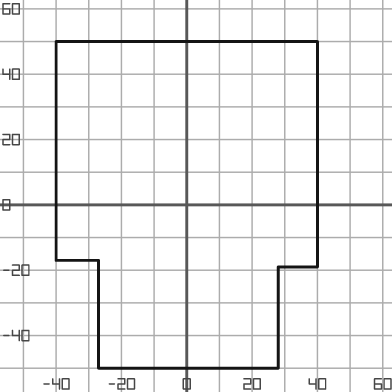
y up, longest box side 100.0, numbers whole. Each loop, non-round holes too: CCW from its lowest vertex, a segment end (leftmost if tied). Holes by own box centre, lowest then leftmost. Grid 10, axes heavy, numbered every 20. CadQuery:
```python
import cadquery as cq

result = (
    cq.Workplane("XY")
    .moveTo(-27.0, -50.0)
    .lineTo(28.0, -50.0)
    .lineTo(28.0, -19.0)
    .lineTo(40.0, -19.0)
    .lineTo(40.0, 50.0)
    .lineTo(-40.0, 50.0)
    .lineTo(-40.0, -17.0)
    .lineTo(-27.0, -17.0)
    .close()
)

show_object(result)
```